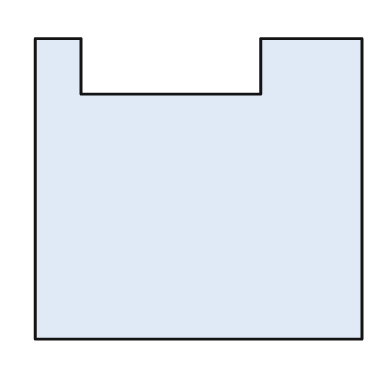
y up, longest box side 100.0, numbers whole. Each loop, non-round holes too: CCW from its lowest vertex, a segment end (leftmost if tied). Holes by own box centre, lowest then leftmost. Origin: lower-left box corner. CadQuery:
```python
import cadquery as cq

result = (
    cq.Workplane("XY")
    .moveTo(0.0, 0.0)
    .lineTo(100.0, 0.0)
    .lineTo(100.0, 92.0)
    .lineTo(69.0, 92.0)
    .lineTo(69.0, 75.0)
    .lineTo(14.0, 75.0)
    .lineTo(14.0, 92.0)
    .lineTo(0.0, 92.0)
    .close()
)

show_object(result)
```